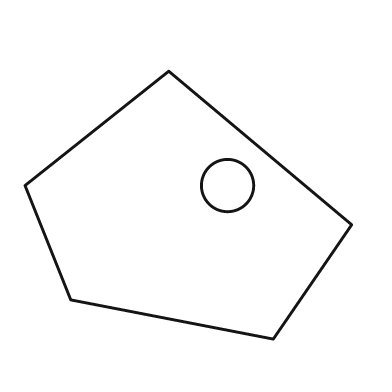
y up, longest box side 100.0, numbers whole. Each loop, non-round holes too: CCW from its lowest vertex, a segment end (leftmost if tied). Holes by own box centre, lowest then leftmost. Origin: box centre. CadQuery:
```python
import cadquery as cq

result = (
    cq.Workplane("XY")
    .moveTo(26.0, -41.0)
    .lineTo(50.0, -6.0)
    .lineTo(-6.0, 41.0)
    .lineTo(-50.0, 6.0)
    .lineTo(-36.0, -29.0)
    .close()
    .moveTo(12.0, 6.0)
    .circle(8.0)
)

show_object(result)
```